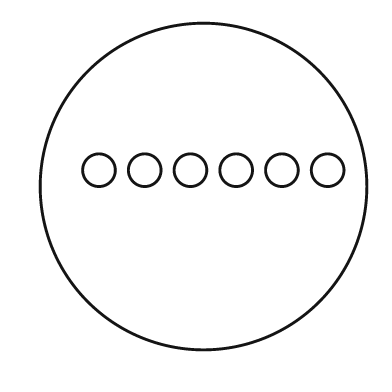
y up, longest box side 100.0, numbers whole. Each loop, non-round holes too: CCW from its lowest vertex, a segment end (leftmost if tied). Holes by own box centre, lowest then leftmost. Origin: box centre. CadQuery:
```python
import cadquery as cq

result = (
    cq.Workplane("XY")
    .moveTo(0.0, 0.0)
    .circle(50.0)
    .moveTo(-32.0, 5.0)
    .circle(5.0)
    .moveTo(-18.0, 5.0)
    .circle(5.0)
    .moveTo(-4.0, 5.0)
    .circle(5.0)
    .moveTo(10.0, 5.0)
    .circle(5.0)
    .moveTo(24.0, 5.0)
    .circle(5.0)
    .moveTo(38.0, 5.0)
    .circle(5.0)
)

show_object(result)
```